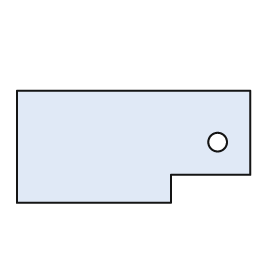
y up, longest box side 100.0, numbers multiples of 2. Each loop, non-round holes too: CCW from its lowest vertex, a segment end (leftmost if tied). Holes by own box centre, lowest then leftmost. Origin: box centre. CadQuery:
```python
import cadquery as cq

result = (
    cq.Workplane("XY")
    .moveTo(-50.0, -24.0)
    .lineTo(16.0, -24.0)
    .lineTo(16.0, -12.0)
    .lineTo(50.0, -12.0)
    .lineTo(50.0, 24.0)
    .lineTo(-50.0, 24.0)
    .close()
    .moveTo(36.0, 2.0)
    .circle(4.0)
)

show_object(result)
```